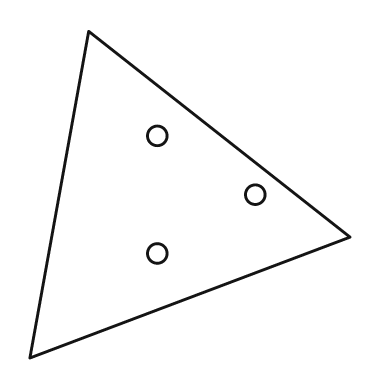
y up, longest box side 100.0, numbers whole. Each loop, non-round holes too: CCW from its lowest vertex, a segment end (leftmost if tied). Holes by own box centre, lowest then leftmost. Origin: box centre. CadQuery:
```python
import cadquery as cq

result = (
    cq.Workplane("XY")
    .moveTo(-49.0, -50.0)
    .lineTo(49.0, -13.0)
    .lineTo(-31.0, 50.0)
    .close()
    .moveTo(-10.0, -18.0)
    .circle(3.0)
    .moveTo(20.0, 0.0)
    .circle(3.0)
    .moveTo(-10.0, 18.0)
    .circle(3.0)
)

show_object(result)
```